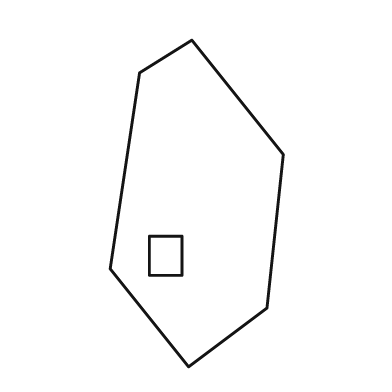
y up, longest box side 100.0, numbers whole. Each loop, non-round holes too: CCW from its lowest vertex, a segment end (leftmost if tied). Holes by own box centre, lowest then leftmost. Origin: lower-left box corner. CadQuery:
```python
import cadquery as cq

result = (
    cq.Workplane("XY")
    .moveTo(24.0, 0.0)
    .lineTo(48.0, 18.0)
    .lineTo(53.0, 65.0)
    .lineTo(25.0, 100.0)
    .lineTo(9.0, 90.0)
    .lineTo(0.0, 30.0)
    .close()
    .moveTo(12.0, 28.0)
    .lineTo(22.0, 28.0)
    .lineTo(22.0, 40.0)
    .lineTo(12.0, 40.0)
    .close()
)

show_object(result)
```